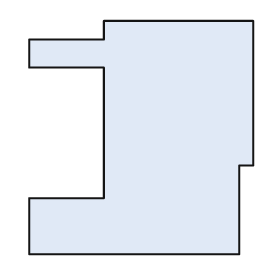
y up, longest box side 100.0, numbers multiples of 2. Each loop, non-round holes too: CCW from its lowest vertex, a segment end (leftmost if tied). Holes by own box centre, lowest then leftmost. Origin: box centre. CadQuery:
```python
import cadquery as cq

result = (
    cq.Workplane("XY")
    .moveTo(-48.0, -50.0)
    .lineTo(42.0, -50.0)
    .lineTo(42.0, -12.0)
    .lineTo(48.0, -12.0)
    .lineTo(48.0, 50.0)
    .lineTo(-16.0, 50.0)
    .lineTo(-16.0, 42.0)
    .lineTo(-48.0, 42.0)
    .lineTo(-48.0, 30.0)
    .lineTo(-16.0, 30.0)
    .lineTo(-16.0, -26.0)
    .lineTo(-48.0, -26.0)
    .close()
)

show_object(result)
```